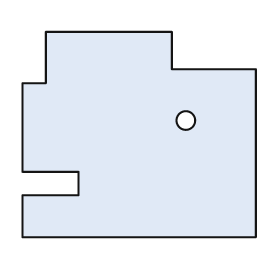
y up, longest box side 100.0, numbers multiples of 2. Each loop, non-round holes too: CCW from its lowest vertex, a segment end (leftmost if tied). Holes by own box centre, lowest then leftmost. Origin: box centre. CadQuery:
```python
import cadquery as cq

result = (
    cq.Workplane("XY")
    .moveTo(-50.0, -44.0)
    .lineTo(50.0, -44.0)
    .lineTo(50.0, 28.0)
    .lineTo(14.0, 28.0)
    .lineTo(14.0, 44.0)
    .lineTo(-40.0, 44.0)
    .lineTo(-40.0, 22.0)
    .lineTo(-50.0, 22.0)
    .lineTo(-50.0, -16.0)
    .lineTo(-26.0, -16.0)
    .lineTo(-26.0, -26.0)
    .lineTo(-50.0, -26.0)
    .close()
    .moveTo(20.0, 6.0)
    .circle(4.0)
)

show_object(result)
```